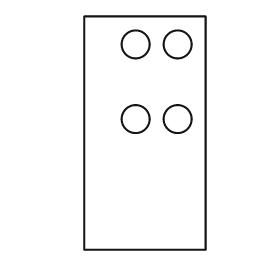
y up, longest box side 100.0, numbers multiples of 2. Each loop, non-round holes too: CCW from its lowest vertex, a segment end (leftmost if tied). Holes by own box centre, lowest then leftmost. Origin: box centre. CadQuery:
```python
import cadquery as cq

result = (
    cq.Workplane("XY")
    .moveTo(-26.0, -50.0)
    .lineTo(26.0, -50.0)
    .lineTo(26.0, 50.0)
    .lineTo(-26.0, 50.0)
    .close()
    .moveTo(-4.0, 6.0)
    .circle(6.0)
    .moveTo(14.0, 6.0)
    .circle(6.0)
    .moveTo(-4.0, 38.0)
    .circle(6.0)
    .moveTo(14.0, 38.0)
    .circle(6.0)
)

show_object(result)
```